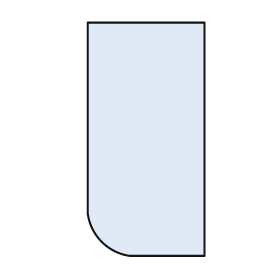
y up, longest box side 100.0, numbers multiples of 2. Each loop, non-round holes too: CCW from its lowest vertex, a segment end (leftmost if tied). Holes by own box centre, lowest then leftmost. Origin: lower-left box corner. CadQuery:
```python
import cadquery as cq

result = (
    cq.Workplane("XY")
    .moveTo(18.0, 0.0)
    .lineTo(50.0, 0.0)
    .lineTo(50.0, 100.0)
    .lineTo(0.0, 100.0)
    .lineTo(0.0, 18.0)
    .threePointArc((6.0, 6.0), (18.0, 0.0))
    .close()
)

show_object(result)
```